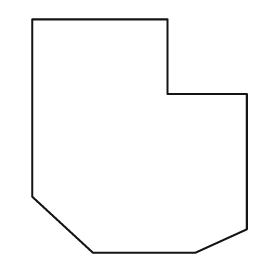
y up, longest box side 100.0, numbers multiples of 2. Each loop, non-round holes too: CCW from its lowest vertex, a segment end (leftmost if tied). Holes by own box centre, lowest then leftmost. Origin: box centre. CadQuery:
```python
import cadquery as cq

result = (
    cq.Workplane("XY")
    .moveTo(-20.0, -50.0)
    .lineTo(24.0, -50.0)
    .lineTo(46.0, -40.0)
    .lineTo(46.0, 18.0)
    .lineTo(12.0, 18.0)
    .lineTo(12.0, 50.0)
    .lineTo(-46.0, 50.0)
    .lineTo(-46.0, -26.0)
    .close()
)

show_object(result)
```